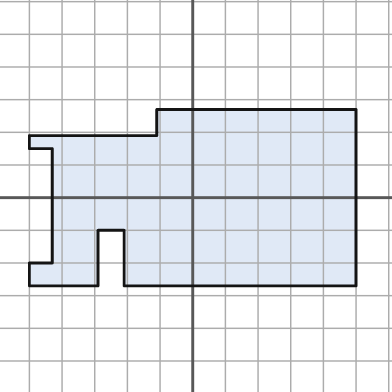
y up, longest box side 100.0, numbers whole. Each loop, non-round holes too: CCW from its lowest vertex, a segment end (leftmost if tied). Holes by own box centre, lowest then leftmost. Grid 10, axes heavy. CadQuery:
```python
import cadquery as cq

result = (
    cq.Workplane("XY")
    .moveTo(-50.0, -27.0)
    .lineTo(-29.0, -27.0)
    .lineTo(-29.0, -10.0)
    .lineTo(-21.0, -10.0)
    .lineTo(-21.0, -27.0)
    .lineTo(50.0, -27.0)
    .lineTo(50.0, 27.0)
    .lineTo(-11.0, 27.0)
    .lineTo(-11.0, 19.0)
    .lineTo(-50.0, 19.0)
    .lineTo(-50.0, 15.0)
    .lineTo(-43.0, 15.0)
    .lineTo(-43.0, -20.0)
    .lineTo(-50.0, -20.0)
    .close()
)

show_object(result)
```